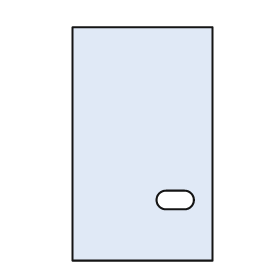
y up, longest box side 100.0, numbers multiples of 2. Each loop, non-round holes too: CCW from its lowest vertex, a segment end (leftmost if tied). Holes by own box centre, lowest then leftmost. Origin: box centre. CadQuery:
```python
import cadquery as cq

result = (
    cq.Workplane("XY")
    .moveTo(-30.0, -50.0)
    .lineTo(30.0, -50.0)
    .lineTo(30.0, 50.0)
    .lineTo(-30.0, 50.0)
    .close()
    .moveTo(10.0, -28.0)
    .lineTo(18.0, -28.0)
    .threePointArc((22.0, -24.0), (18.0, -20.0))
    .lineTo(10.0, -20.0)
    .threePointArc((6.0, -24.0), (10.0, -28.0))
    .close()
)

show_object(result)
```